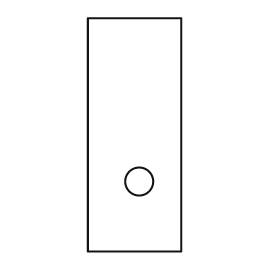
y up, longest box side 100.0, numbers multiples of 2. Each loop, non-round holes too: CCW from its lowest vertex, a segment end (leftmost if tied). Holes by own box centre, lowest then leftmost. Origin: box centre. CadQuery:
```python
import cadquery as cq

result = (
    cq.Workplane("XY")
    .moveTo(-20.0, -50.0)
    .lineTo(20.0, -50.0)
    .lineTo(20.0, 50.0)
    .lineTo(-20.0, 50.0)
    .close()
    .moveTo(2.0, -20.0)
    .circle(6.0)
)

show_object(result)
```